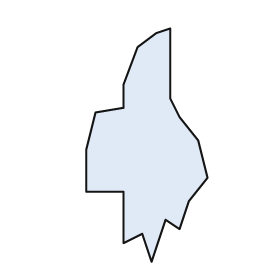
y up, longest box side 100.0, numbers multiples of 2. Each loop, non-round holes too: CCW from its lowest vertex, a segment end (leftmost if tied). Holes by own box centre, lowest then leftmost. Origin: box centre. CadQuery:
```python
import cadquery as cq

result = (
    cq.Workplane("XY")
    .moveTo(2.0, -50.0)
    .lineTo(8.0, -32.0)
    .lineTo(14.0, -36.0)
    .lineTo(18.0, -24.0)
    .lineTo(26.0, -14.0)
    .lineTo(22.0, 2.0)
    .lineTo(14.0, 12.0)
    .lineTo(10.0, 20.0)
    .lineTo(10.0, 50.0)
    .lineTo(4.0, 48.0)
    .lineTo(-4.0, 42.0)
    .lineTo(-10.0, 26.0)
    .lineTo(-10.0, 16.0)
    .lineTo(-22.0, 14.0)
    .lineTo(-26.0, -2.0)
    .lineTo(-26.0, -20.0)
    .lineTo(-10.0, -20.0)
    .lineTo(-10.0, -42.0)
    .lineTo(-2.0, -38.0)
    .close()
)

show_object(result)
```